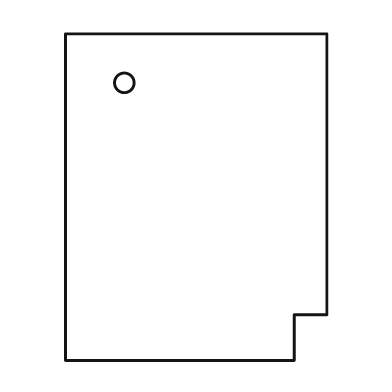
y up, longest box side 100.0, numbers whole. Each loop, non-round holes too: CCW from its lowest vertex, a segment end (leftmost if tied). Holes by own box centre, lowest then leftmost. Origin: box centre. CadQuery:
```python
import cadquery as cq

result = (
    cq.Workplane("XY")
    .moveTo(-40.0, -50.0)
    .lineTo(30.0, -50.0)
    .lineTo(30.0, -36.0)
    .lineTo(40.0, -36.0)
    .lineTo(40.0, 50.0)
    .lineTo(-40.0, 50.0)
    .close()
    .moveTo(-22.0, 35.0)
    .circle(3.0)
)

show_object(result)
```